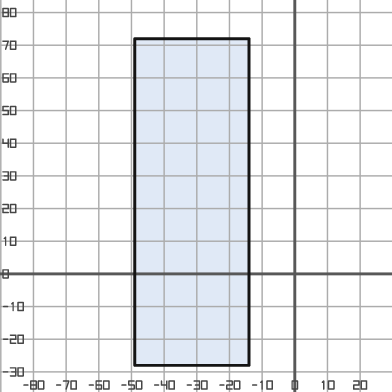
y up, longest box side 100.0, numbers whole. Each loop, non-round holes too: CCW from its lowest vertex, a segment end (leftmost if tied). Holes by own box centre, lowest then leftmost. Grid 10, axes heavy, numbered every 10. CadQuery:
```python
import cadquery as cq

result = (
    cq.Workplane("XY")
    .moveTo(-49.0, -28.0)
    .lineTo(-14.0, -28.0)
    .lineTo(-14.0, 72.0)
    .lineTo(-49.0, 72.0)
    .close()
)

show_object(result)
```